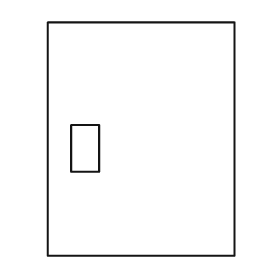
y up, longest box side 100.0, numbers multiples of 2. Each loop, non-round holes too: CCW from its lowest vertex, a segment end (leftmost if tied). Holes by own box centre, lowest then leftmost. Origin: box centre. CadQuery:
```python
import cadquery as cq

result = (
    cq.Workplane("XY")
    .moveTo(-40.0, -50.0)
    .lineTo(40.0, -50.0)
    .lineTo(40.0, 50.0)
    .lineTo(-40.0, 50.0)
    .close()
    .moveTo(-30.0, -14.0)
    .lineTo(-18.0, -14.0)
    .lineTo(-18.0, 6.0)
    .lineTo(-30.0, 6.0)
    .close()
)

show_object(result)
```